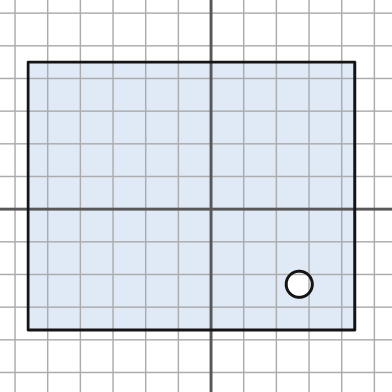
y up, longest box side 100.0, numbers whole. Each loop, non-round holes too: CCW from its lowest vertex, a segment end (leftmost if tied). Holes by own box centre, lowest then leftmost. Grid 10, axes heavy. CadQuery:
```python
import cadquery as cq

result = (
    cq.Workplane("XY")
    .moveTo(-56.0, -37.0)
    .lineTo(44.0, -37.0)
    .lineTo(44.0, 45.0)
    .lineTo(-56.0, 45.0)
    .close()
    .moveTo(27.0, -23.0)
    .circle(4.0)
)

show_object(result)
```